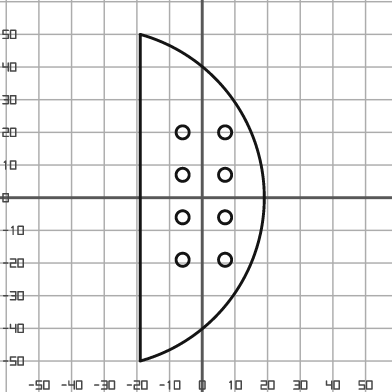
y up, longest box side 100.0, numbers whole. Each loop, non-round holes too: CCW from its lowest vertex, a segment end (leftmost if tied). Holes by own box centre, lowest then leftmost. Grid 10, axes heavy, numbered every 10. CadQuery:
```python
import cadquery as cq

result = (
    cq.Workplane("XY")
    .moveTo(-19.0, -50.0)
    .threePointArc((19.0, 0.0), (-19.0, 50.0))
    .close()
    .moveTo(-6.0, -19.0)
    .circle(2.0)
    .moveTo(7.0, -19.0)
    .circle(2.0)
    .moveTo(-6.0, -6.0)
    .circle(2.0)
    .moveTo(7.0, -6.0)
    .circle(2.0)
    .moveTo(-6.0, 7.0)
    .circle(2.0)
    .moveTo(7.0, 7.0)
    .circle(2.0)
    .moveTo(-6.0, 20.0)
    .circle(2.0)
    .moveTo(7.0, 20.0)
    .circle(2.0)
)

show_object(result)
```